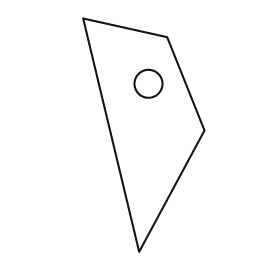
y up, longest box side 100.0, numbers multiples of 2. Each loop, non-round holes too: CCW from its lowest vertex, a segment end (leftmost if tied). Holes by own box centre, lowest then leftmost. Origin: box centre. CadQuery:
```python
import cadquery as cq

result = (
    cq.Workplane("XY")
    .moveTo(-2.0, -50.0)
    .lineTo(26.0, 2.0)
    .lineTo(10.0, 42.0)
    .lineTo(-26.0, 50.0)
    .close()
    .moveTo(2.0, 22.0)
    .circle(6.0)
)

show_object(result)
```